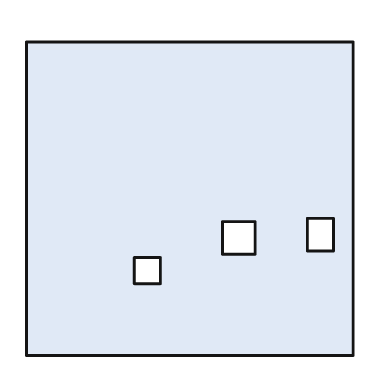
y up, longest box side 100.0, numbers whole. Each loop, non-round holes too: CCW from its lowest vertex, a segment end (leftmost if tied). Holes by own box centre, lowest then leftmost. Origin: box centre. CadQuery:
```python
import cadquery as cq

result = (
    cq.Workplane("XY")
    .moveTo(-50.0, -48.0)
    .lineTo(50.0, -48.0)
    .lineTo(50.0, 48.0)
    .lineTo(-50.0, 48.0)
    .close()
    .moveTo(-17.0, -26.0)
    .lineTo(-9.0, -26.0)
    .lineTo(-9.0, -18.0)
    .lineTo(-17.0, -18.0)
    .close()
    .moveTo(10.0, -17.0)
    .lineTo(20.0, -17.0)
    .lineTo(20.0, -7.0)
    .lineTo(10.0, -7.0)
    .close()
    .moveTo(36.0, -16.0)
    .lineTo(44.0, -16.0)
    .lineTo(44.0, -6.0)
    .lineTo(36.0, -6.0)
    .close()
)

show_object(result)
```